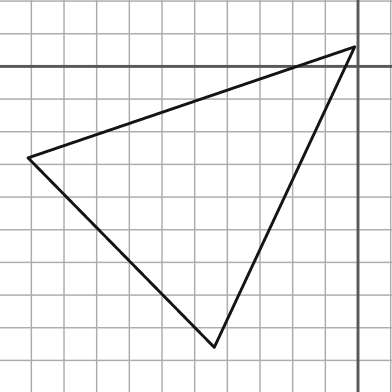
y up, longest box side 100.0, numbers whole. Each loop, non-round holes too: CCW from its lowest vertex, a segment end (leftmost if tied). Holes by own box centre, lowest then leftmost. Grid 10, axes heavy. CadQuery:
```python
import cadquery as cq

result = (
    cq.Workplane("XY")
    .moveTo(-44.0, -86.0)
    .lineTo(-1.0, 6.0)
    .lineTo(-101.0, -28.0)
    .close()
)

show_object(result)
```